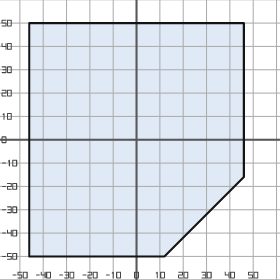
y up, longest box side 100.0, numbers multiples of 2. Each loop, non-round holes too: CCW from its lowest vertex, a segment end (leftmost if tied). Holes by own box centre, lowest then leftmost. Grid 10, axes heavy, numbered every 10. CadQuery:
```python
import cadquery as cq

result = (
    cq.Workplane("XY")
    .moveTo(-46.0, -50.0)
    .lineTo(12.0, -50.0)
    .lineTo(46.0, -16.0)
    .lineTo(46.0, 50.0)
    .lineTo(-46.0, 50.0)
    .close()
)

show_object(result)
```